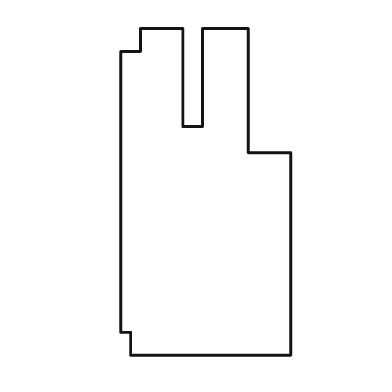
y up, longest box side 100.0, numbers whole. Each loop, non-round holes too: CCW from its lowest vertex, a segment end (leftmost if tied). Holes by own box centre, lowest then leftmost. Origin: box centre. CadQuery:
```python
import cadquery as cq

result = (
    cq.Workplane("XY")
    .moveTo(-23.0, -50.0)
    .lineTo(26.0, -50.0)
    .lineTo(26.0, 12.0)
    .lineTo(13.0, 12.0)
    .lineTo(13.0, 50.0)
    .lineTo(-1.0, 50.0)
    .lineTo(-1.0, 20.0)
    .lineTo(-7.0, 20.0)
    .lineTo(-7.0, 50.0)
    .lineTo(-20.0, 50.0)
    .lineTo(-20.0, 43.0)
    .lineTo(-26.0, 43.0)
    .lineTo(-26.0, -43.0)
    .lineTo(-23.0, -43.0)
    .close()
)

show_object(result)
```